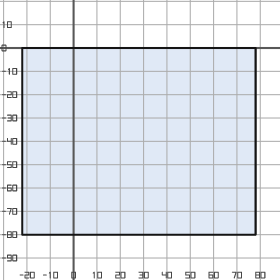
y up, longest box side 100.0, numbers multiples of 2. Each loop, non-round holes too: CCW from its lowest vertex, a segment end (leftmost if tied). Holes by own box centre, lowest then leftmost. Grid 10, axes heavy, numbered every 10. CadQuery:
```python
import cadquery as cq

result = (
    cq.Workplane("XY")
    .moveTo(-22.0, -80.0)
    .lineTo(78.0, -80.0)
    .lineTo(78.0, 0.0)
    .lineTo(-22.0, 0.0)
    .close()
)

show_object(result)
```